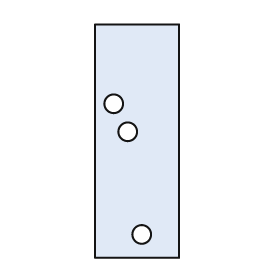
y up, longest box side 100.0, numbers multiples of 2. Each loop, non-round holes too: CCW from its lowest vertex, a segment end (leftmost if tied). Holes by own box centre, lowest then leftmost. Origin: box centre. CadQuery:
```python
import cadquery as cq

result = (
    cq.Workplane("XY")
    .moveTo(-18.0, -50.0)
    .lineTo(18.0, -50.0)
    .lineTo(18.0, 50.0)
    .lineTo(-18.0, 50.0)
    .close()
    .moveTo(2.0, -40.0)
    .circle(4.0)
    .moveTo(-4.0, 4.0)
    .circle(4.0)
    .moveTo(-10.0, 16.0)
    .circle(4.0)
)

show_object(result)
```